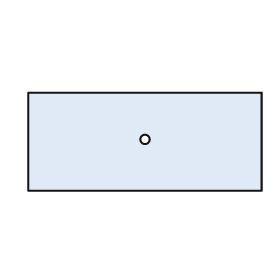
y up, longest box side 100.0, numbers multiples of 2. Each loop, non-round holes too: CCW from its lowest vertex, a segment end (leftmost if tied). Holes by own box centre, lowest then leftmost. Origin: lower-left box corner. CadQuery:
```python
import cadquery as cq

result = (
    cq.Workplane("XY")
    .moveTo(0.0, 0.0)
    .lineTo(100.0, 0.0)
    .lineTo(100.0, 42.0)
    .lineTo(0.0, 42.0)
    .close()
    .moveTo(50.0, 22.0)
    .circle(2.0)
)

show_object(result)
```